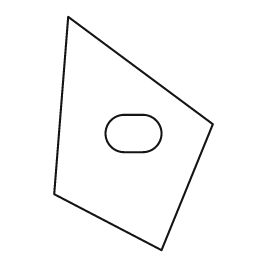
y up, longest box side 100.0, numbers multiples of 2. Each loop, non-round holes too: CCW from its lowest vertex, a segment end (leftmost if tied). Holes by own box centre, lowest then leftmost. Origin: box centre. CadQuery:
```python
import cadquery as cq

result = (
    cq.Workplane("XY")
    .moveTo(12.0, -50.0)
    .lineTo(34.0, 4.0)
    .lineTo(-28.0, 50.0)
    .lineTo(-34.0, -26.0)
    .close()
    .moveTo(-4.0, -8.0)
    .lineTo(4.0, -8.0)
    .threePointArc((12.0, 0.0), (4.0, 8.0))
    .lineTo(-4.0, 8.0)
    .threePointArc((-12.0, 0.0), (-4.0, -8.0))
    .close()
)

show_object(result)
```